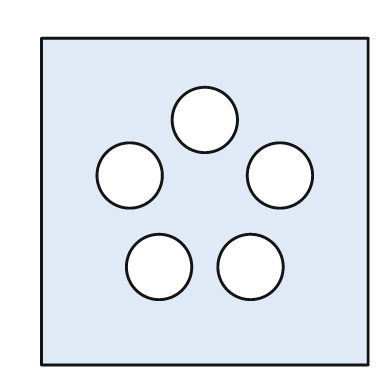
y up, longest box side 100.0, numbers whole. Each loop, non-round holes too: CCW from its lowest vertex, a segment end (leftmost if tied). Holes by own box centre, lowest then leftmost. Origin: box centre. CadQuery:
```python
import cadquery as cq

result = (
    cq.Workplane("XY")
    .moveTo(-50.0, -50.0)
    .lineTo(50.0, -50.0)
    .lineTo(50.0, 50.0)
    .lineTo(-50.0, 50.0)
    .close()
    .moveTo(-14.0, -20.0)
    .circle(10.0)
    .moveTo(14.0, -20.0)
    .circle(10.0)
    .moveTo(-23.0, 8.0)
    .circle(10.0)
    .moveTo(23.0, 8.0)
    .circle(10.0)
    .moveTo(0.0, 25.0)
    .circle(10.0)
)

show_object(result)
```